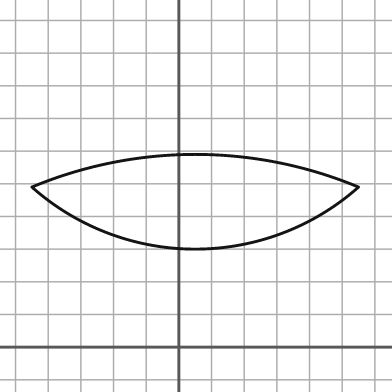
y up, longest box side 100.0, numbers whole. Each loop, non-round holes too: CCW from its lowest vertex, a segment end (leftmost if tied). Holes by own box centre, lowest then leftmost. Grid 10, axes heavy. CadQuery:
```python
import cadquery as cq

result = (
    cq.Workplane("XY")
    .moveTo(-45.0, 49.0)
    .threePointArc((5.0, 30.0), (55.0, 49.0))
    .threePointArc((5.0, 59.0), (-45.0, 49.0))
    .close()
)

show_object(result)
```